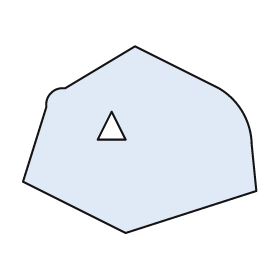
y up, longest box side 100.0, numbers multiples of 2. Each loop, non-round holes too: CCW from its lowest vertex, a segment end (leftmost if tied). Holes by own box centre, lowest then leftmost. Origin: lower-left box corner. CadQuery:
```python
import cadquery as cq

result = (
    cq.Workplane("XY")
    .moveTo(44.0, 0.0)
    .lineTo(100.0, 18.0)
    .lineTo(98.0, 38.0)
    .threePointArc((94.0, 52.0), (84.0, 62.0))
    .lineTo(48.0, 80.0)
    .lineTo(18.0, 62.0)
    .threePointArc((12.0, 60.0), (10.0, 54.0))
    .lineTo(0.0, 22.0)
    .close()
    .moveTo(32.0, 40.0)
    .lineTo(44.0, 40.0)
    .lineTo(38.0, 52.0)
    .close()
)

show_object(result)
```